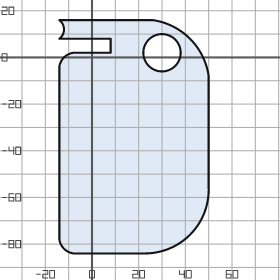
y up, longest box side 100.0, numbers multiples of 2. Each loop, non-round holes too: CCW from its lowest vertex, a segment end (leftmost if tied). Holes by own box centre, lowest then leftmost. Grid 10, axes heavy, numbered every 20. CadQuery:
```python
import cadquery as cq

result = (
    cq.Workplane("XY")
    .moveTo(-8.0, -84.0)
    .lineTo(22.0, -84.0)
    .threePointArc((42.0, -76.0), (50.0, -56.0))
    .lineTo(50.0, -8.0)
    .threePointArc((42.0, 8.0), (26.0, 16.0))
    .lineTo(-14.0, 16.0)
    .threePointArc((-12.0, 12.0), (-14.0, 8.0))
    .lineTo(8.0, 8.0)
    .lineTo(8.0, 2.0)
    .lineTo(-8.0, 2.0)
    .threePointArc((-12.0, 0.0), (-14.0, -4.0))
    .lineTo(-14.0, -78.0)
    .threePointArc((-12.0, -82.0), (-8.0, -84.0))
    .close()
    .moveTo(30.0, 2.0)
    .circle(8.0)
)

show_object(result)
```